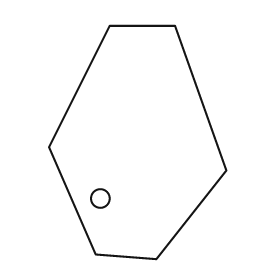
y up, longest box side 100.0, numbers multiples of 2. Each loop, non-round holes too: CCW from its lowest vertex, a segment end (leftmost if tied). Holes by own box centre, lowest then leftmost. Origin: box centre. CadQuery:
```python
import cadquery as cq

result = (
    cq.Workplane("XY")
    .moveTo(8.0, -50.0)
    .lineTo(38.0, -12.0)
    .lineTo(16.0, 50.0)
    .lineTo(-12.0, 50.0)
    .lineTo(-38.0, -2.0)
    .lineTo(-18.0, -48.0)
    .close()
    .moveTo(-16.0, -24.0)
    .circle(4.0)
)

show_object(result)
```